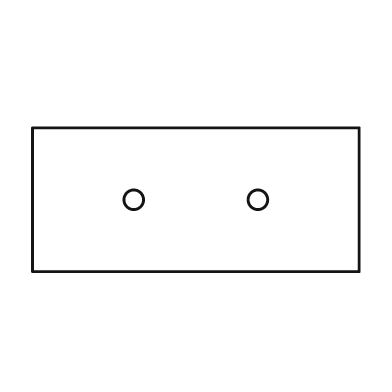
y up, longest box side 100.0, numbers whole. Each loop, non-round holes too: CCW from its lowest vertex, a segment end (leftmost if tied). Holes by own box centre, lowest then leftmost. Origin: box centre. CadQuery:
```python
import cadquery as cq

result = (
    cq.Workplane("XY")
    .moveTo(-50.0, -22.0)
    .lineTo(50.0, -22.0)
    .lineTo(50.0, 22.0)
    .lineTo(-50.0, 22.0)
    .close()
    .moveTo(-19.0, 0.0)
    .circle(3.0)
    .moveTo(19.0, 0.0)
    .circle(3.0)
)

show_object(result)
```